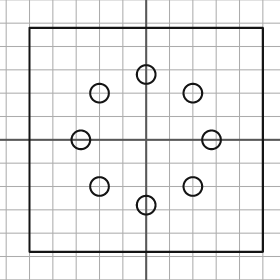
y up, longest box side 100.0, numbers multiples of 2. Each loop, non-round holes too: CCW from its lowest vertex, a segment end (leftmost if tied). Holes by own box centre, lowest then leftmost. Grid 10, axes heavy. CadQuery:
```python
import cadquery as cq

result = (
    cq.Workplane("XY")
    .moveTo(-50.0, -48.0)
    .lineTo(50.0, -48.0)
    .lineTo(50.0, 48.0)
    .lineTo(-50.0, 48.0)
    .close()
    .moveTo(0.0, -28.0)
    .circle(4.0)
    .moveTo(-20.0, -20.0)
    .circle(4.0)
    .moveTo(20.0, -20.0)
    .circle(4.0)
    .moveTo(-28.0, 0.0)
    .circle(4.0)
    .moveTo(28.0, 0.0)
    .circle(4.0)
    .moveTo(-20.0, 20.0)
    .circle(4.0)
    .moveTo(20.0, 20.0)
    .circle(4.0)
    .moveTo(0.0, 28.0)
    .circle(4.0)
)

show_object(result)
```